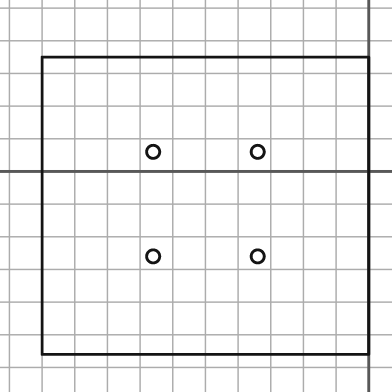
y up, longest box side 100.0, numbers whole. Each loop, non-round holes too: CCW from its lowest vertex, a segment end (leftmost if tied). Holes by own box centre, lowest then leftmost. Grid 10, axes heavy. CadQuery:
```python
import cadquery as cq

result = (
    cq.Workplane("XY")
    .moveTo(-100.0, -56.0)
    .lineTo(0.0, -56.0)
    .lineTo(0.0, 35.0)
    .lineTo(-100.0, 35.0)
    .close()
    .moveTo(-66.0, -26.0)
    .circle(2.0)
    .moveTo(-34.0, -26.0)
    .circle(2.0)
    .moveTo(-66.0, 6.0)
    .circle(2.0)
    .moveTo(-34.0, 6.0)
    .circle(2.0)
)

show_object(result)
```